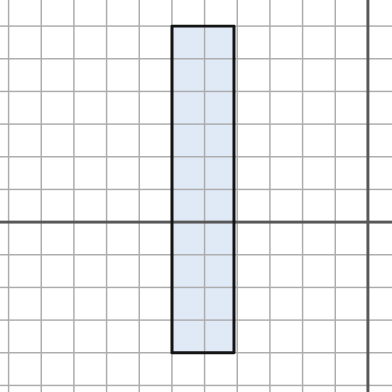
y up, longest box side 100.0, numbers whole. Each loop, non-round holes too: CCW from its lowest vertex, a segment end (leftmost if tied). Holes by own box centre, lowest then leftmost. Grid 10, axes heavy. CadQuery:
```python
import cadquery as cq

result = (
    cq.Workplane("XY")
    .moveTo(-60.0, -40.0)
    .lineTo(-41.0, -40.0)
    .lineTo(-41.0, 60.0)
    .lineTo(-60.0, 60.0)
    .close()
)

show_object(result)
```